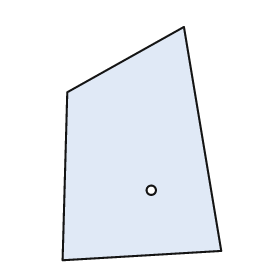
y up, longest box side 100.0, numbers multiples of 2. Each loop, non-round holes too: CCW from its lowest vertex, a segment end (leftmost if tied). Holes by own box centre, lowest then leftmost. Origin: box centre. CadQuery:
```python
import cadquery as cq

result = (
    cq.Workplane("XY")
    .moveTo(-34.0, -50.0)
    .lineTo(34.0, -46.0)
    .lineTo(18.0, 50.0)
    .lineTo(-32.0, 22.0)
    .close()
    .moveTo(4.0, -20.0)
    .circle(2.0)
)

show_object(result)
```